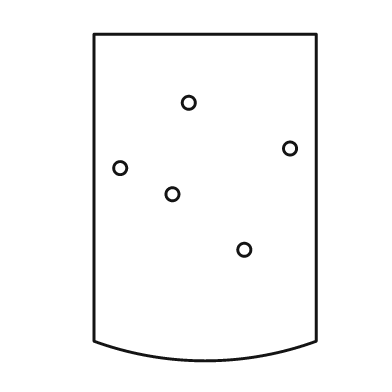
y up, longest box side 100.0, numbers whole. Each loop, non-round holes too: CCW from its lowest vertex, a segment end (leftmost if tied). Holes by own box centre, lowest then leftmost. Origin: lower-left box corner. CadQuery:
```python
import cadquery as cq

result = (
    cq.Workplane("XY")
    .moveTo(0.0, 6.0)
    .threePointArc((34.0, 0.0), (68.0, 6.0))
    .lineTo(68.0, 100.0)
    .lineTo(0.0, 100.0)
    .close()
    .moveTo(46.0, 34.0)
    .circle(2.0)
    .moveTo(24.0, 51.0)
    .circle(2.0)
    .moveTo(8.0, 59.0)
    .circle(2.0)
    .moveTo(60.0, 65.0)
    .circle(2.0)
    .moveTo(29.0, 79.0)
    .circle(2.0)
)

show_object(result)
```